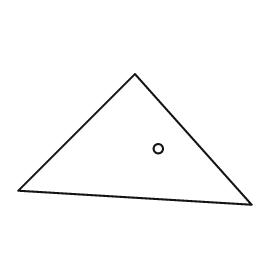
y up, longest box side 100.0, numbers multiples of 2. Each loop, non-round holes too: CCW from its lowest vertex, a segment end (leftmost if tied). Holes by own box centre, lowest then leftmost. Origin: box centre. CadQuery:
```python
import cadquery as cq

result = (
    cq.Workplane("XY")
    .moveTo(50.0, -28.0)
    .lineTo(0.0, 28.0)
    .lineTo(-50.0, -22.0)
    .close()
    .moveTo(10.0, -4.0)
    .circle(2.0)
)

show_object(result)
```